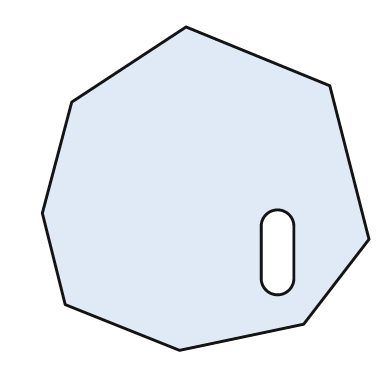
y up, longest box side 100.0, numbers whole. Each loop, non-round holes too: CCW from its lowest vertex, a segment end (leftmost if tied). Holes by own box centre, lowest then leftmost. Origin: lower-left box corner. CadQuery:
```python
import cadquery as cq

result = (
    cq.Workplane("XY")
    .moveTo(42.0, 0.0)
    .lineTo(80.0, 8.0)
    .lineTo(100.0, 34.0)
    .lineTo(88.0, 81.0)
    .lineTo(44.0, 99.0)
    .lineTo(9.0, 76.0)
    .lineTo(0.0, 42.0)
    .lineTo(7.0, 14.0)
    .close()
    .moveTo(67.0, 22.0)
    .threePointArc((72.0, 17.0), (77.0, 22.0))
    .lineTo(77.0, 38.0)
    .threePointArc((72.0, 43.0), (67.0, 38.0))
    .close()
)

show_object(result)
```